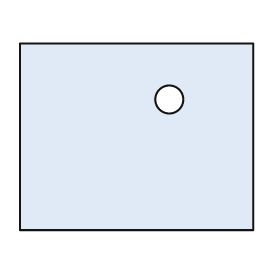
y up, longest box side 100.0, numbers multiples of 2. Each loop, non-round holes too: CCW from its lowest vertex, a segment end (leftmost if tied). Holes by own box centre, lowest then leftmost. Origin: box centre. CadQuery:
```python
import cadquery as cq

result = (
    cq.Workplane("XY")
    .moveTo(-50.0, -40.0)
    .lineTo(50.0, -40.0)
    .lineTo(50.0, 40.0)
    .lineTo(-50.0, 40.0)
    .close()
    .moveTo(14.0, 16.0)
    .circle(6.0)
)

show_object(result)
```